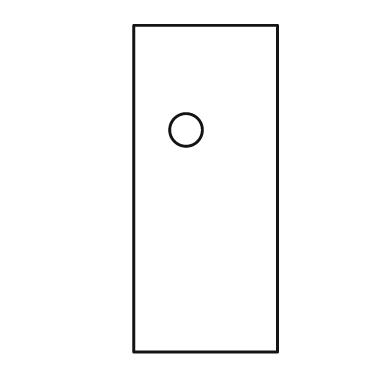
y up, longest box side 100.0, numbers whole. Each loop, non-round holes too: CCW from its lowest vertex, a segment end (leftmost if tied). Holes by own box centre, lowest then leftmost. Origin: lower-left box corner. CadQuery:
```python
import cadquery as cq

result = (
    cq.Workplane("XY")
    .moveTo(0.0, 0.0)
    .lineTo(44.0, 0.0)
    .lineTo(44.0, 100.0)
    .lineTo(0.0, 100.0)
    .close()
    .moveTo(16.0, 68.0)
    .circle(5.0)
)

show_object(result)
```